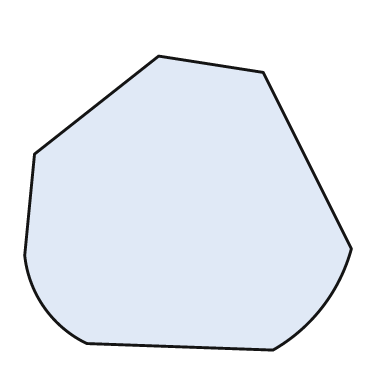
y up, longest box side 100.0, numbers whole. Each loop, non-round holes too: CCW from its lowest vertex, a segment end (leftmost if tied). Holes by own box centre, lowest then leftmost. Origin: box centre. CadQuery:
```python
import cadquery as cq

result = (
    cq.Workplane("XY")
    .moveTo(26.0, -45.0)
    .threePointArc((41.0, -32.0), (50.0, -14.0))
    .lineTo(23.0, 40.0)
    .lineTo(-9.0, 45.0)
    .lineTo(-47.0, 15.0)
    .lineTo(-50.0, -16.0)
    .threePointArc((-44.0, -32.0), (-31.0, -43.0))
    .close()
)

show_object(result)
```